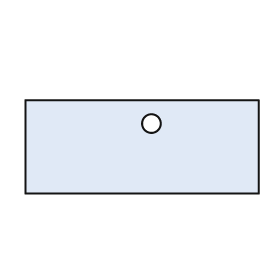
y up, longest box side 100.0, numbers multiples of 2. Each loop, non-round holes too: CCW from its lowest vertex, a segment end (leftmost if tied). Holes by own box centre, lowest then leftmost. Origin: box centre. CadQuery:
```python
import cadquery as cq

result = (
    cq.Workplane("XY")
    .moveTo(-50.0, -20.0)
    .lineTo(50.0, -20.0)
    .lineTo(50.0, 20.0)
    .lineTo(-50.0, 20.0)
    .close()
    .moveTo(4.0, 10.0)
    .circle(4.0)
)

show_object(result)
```